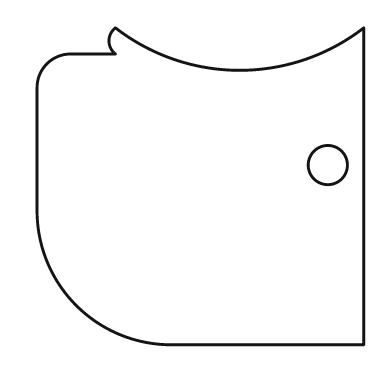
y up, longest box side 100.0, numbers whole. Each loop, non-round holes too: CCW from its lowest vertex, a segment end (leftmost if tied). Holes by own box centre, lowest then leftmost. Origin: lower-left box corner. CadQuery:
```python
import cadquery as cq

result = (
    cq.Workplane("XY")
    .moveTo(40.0, 0.0)
    .lineTo(100.0, 0.0)
    .lineTo(100.0, 97.0)
    .threePointArc((62.0, 84.0), (24.0, 97.0))
    .threePointArc((22.0, 93.0), (24.0, 89.0))
    .lineTo(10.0, 89.0)
    .threePointArc((3.0, 86.0), (0.0, 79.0))
    .lineTo(0.0, 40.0)
    .threePointArc((12.0, 12.0), (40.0, 0.0))
    .close()
    .moveTo(89.0, 55.0)
    .circle(6.0)
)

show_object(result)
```